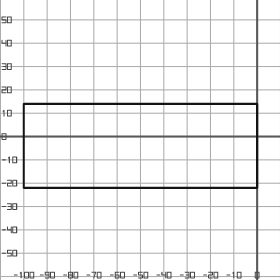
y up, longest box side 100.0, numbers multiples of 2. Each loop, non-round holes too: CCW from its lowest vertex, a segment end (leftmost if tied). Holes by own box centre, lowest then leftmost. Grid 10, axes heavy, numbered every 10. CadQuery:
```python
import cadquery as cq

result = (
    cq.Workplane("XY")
    .moveTo(-100.0, -22.0)
    .lineTo(0.0, -22.0)
    .lineTo(0.0, 14.0)
    .lineTo(-100.0, 14.0)
    .close()
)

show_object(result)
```